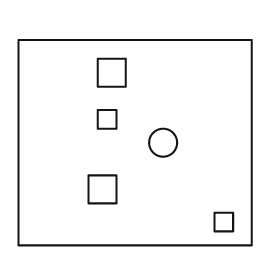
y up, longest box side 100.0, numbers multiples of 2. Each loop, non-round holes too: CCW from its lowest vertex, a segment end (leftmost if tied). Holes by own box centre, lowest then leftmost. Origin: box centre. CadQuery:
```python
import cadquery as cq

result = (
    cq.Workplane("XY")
    .moveTo(-50.0, -44.0)
    .lineTo(50.0, -44.0)
    .lineTo(50.0, 44.0)
    .lineTo(-50.0, 44.0)
    .close()
    .moveTo(34.0, -38.0)
    .lineTo(42.0, -38.0)
    .lineTo(42.0, -30.0)
    .lineTo(34.0, -30.0)
    .close()
    .moveTo(-20.0, -26.0)
    .lineTo(-8.0, -26.0)
    .lineTo(-8.0, -14.0)
    .lineTo(-20.0, -14.0)
    .close()
    .moveTo(12.0, 0.0)
    .circle(6.0)
    .moveTo(-16.0, 6.0)
    .lineTo(-8.0, 6.0)
    .lineTo(-8.0, 14.0)
    .lineTo(-16.0, 14.0)
    .close()
    .moveTo(-16.0, 24.0)
    .lineTo(-4.0, 24.0)
    .lineTo(-4.0, 36.0)
    .lineTo(-16.0, 36.0)
    .close()
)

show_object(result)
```